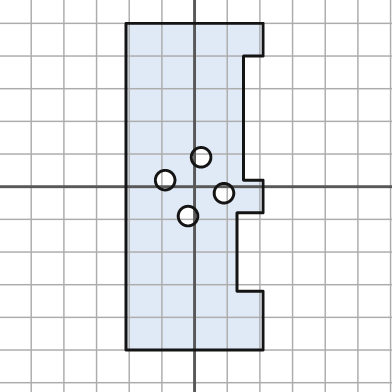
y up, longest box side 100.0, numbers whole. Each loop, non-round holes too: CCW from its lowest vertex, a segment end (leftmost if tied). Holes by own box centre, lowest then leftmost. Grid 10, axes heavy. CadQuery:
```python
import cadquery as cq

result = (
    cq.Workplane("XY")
    .moveTo(-21.0, -50.0)
    .lineTo(21.0, -50.0)
    .lineTo(21.0, -32.0)
    .lineTo(13.0, -32.0)
    .lineTo(13.0, -8.0)
    .lineTo(21.0, -8.0)
    .lineTo(21.0, 2.0)
    .lineTo(15.0, 2.0)
    .lineTo(15.0, 40.0)
    .lineTo(21.0, 40.0)
    .lineTo(21.0, 50.0)
    .lineTo(-21.0, 50.0)
    .close()
    .moveTo(-2.0, -9.0)
    .circle(3.0)
    .moveTo(9.0, -2.0)
    .circle(3.0)
    .moveTo(-9.0, 2.0)
    .circle(3.0)
    .moveTo(2.0, 9.0)
    .circle(3.0)
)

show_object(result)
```